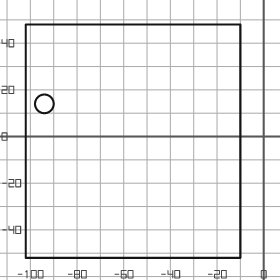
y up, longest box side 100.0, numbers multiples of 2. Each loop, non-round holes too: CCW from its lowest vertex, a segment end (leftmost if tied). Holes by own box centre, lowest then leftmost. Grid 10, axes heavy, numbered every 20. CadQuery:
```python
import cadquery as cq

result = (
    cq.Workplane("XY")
    .moveTo(-102.0, -52.0)
    .lineTo(-10.0, -52.0)
    .lineTo(-10.0, 48.0)
    .lineTo(-102.0, 48.0)
    .close()
    .moveTo(-94.0, 14.0)
    .circle(4.0)
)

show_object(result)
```